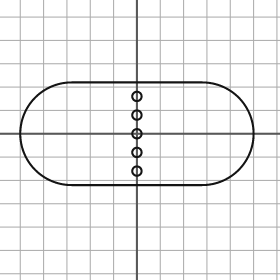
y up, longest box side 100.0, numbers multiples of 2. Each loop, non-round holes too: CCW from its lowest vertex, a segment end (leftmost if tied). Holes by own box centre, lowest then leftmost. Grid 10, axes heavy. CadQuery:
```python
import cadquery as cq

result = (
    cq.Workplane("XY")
    .moveTo(-28.0, -22.0)
    .lineTo(28.0, -22.0)
    .threePointArc((50.0, 0.0), (28.0, 22.0))
    .lineTo(-28.0, 22.0)
    .threePointArc((-50.0, 0.0), (-28.0, -22.0))
    .close()
    .moveTo(0.0, -16.0)
    .circle(2.0)
    .moveTo(0.0, -8.0)
    .circle(2.0)
    .moveTo(0.0, 0.0)
    .circle(2.0)
    .moveTo(0.0, 8.0)
    .circle(2.0)
    .moveTo(0.0, 16.0)
    .circle(2.0)
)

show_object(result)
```